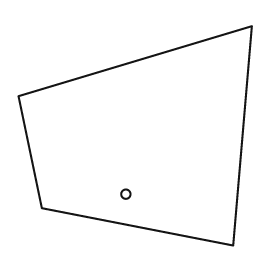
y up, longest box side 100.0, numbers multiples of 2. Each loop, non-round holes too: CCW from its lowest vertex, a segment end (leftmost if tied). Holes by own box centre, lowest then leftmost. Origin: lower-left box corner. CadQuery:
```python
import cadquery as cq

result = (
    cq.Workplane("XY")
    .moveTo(92.0, 0.0)
    .lineTo(100.0, 94.0)
    .lineTo(0.0, 64.0)
    .lineTo(10.0, 16.0)
    .close()
    .moveTo(46.0, 22.0)
    .circle(2.0)
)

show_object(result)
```